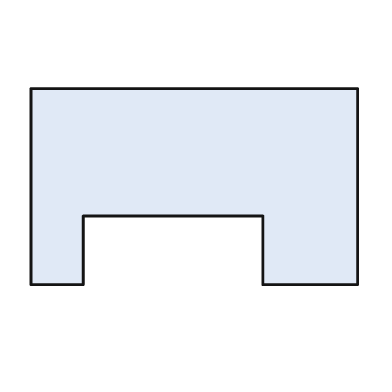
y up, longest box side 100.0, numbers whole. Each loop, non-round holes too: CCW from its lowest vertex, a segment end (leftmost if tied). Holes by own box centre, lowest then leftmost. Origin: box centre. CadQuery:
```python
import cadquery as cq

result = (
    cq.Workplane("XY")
    .moveTo(-50.0, -30.0)
    .lineTo(-34.0, -30.0)
    .lineTo(-34.0, -9.0)
    .lineTo(21.0, -9.0)
    .lineTo(21.0, -30.0)
    .lineTo(50.0, -30.0)
    .lineTo(50.0, 30.0)
    .lineTo(-50.0, 30.0)
    .close()
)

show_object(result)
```